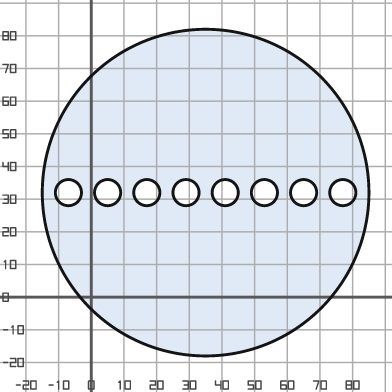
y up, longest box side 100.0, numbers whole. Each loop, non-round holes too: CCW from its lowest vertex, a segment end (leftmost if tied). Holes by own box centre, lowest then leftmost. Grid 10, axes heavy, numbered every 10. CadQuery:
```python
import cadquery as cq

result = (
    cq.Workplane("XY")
    .moveTo(35.0, 32.0)
    .circle(50.0)
    .moveTo(-7.0, 32.0)
    .circle(4.0)
    .moveTo(5.0, 32.0)
    .circle(4.0)
    .moveTo(17.0, 32.0)
    .circle(4.0)
    .moveTo(29.0, 32.0)
    .circle(4.0)
    .moveTo(41.0, 32.0)
    .circle(4.0)
    .moveTo(53.0, 32.0)
    .circle(4.0)
    .moveTo(65.0, 32.0)
    .circle(4.0)
    .moveTo(77.0, 32.0)
    .circle(4.0)
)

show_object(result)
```